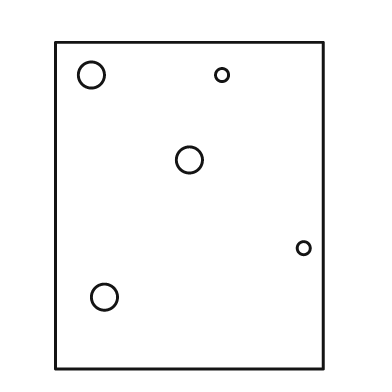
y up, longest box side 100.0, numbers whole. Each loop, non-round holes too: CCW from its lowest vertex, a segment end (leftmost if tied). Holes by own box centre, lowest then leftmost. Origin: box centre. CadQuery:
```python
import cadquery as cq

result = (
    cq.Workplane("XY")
    .moveTo(-41.0, -50.0)
    .lineTo(41.0, -50.0)
    .lineTo(41.0, 50.0)
    .lineTo(-41.0, 50.0)
    .close()
    .moveTo(-26.0, -28.0)
    .circle(4.0)
    .moveTo(35.0, -13.0)
    .circle(2.0)
    .moveTo(0.0, 14.0)
    .circle(4.0)
    .moveTo(-30.0, 40.0)
    .circle(4.0)
    .moveTo(10.0, 40.0)
    .circle(2.0)
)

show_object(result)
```